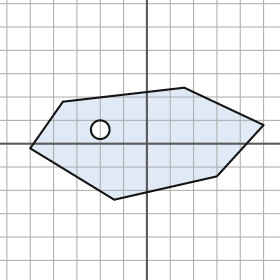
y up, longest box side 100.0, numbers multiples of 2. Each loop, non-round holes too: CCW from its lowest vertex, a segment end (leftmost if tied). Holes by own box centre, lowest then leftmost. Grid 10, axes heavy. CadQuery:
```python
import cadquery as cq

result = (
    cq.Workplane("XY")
    .moveTo(-14.0, -24.0)
    .lineTo(30.0, -14.0)
    .lineTo(50.0, 8.0)
    .lineTo(16.0, 24.0)
    .lineTo(-36.0, 18.0)
    .lineTo(-50.0, -2.0)
    .close()
    .moveTo(-20.0, 6.0)
    .circle(4.0)
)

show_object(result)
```